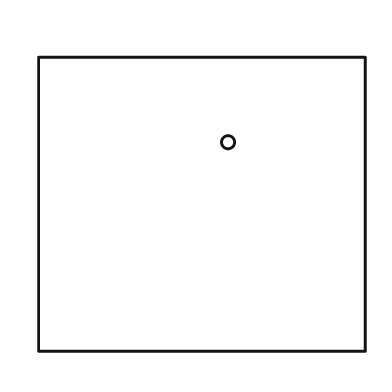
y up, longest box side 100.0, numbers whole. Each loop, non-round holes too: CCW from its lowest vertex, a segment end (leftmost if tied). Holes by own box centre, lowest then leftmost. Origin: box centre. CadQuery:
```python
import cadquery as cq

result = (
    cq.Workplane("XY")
    .moveTo(-50.0, -45.0)
    .lineTo(50.0, -45.0)
    .lineTo(50.0, 45.0)
    .lineTo(-50.0, 45.0)
    .close()
    .moveTo(8.0, 19.0)
    .circle(2.0)
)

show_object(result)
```